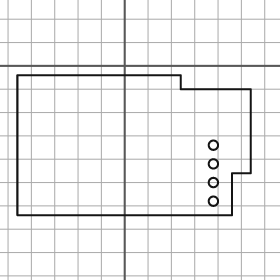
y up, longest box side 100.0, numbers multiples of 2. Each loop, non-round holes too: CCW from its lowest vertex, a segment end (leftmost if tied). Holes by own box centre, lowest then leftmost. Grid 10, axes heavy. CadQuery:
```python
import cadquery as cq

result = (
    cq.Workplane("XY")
    .moveTo(-46.0, -64.0)
    .lineTo(46.0, -64.0)
    .lineTo(46.0, -46.0)
    .lineTo(54.0, -46.0)
    .lineTo(54.0, -10.0)
    .lineTo(24.0, -10.0)
    .lineTo(24.0, -4.0)
    .lineTo(-46.0, -4.0)
    .close()
    .moveTo(38.0, -58.0)
    .circle(2.0)
    .moveTo(38.0, -50.0)
    .circle(2.0)
    .moveTo(38.0, -42.0)
    .circle(2.0)
    .moveTo(38.0, -34.0)
    .circle(2.0)
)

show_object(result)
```